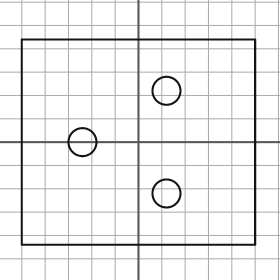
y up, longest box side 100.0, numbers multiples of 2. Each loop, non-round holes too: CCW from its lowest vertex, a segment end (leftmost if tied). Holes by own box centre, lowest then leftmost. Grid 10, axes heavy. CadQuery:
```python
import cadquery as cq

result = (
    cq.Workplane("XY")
    .moveTo(-50.0, -44.0)
    .lineTo(50.0, -44.0)
    .lineTo(50.0, 44.0)
    .lineTo(-50.0, 44.0)
    .close()
    .moveTo(12.0, -22.0)
    .circle(6.0)
    .moveTo(-24.0, 0.0)
    .circle(6.0)
    .moveTo(12.0, 22.0)
    .circle(6.0)
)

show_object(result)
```